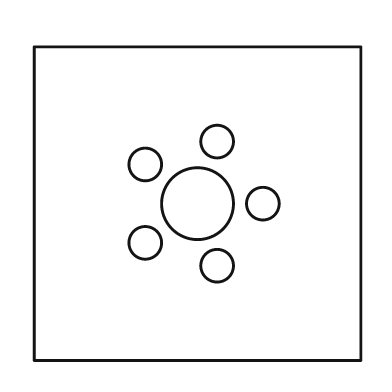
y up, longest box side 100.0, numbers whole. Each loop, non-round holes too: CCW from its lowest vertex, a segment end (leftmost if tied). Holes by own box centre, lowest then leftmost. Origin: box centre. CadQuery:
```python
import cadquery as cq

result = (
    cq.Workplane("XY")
    .moveTo(-50.0, -48.0)
    .lineTo(50.0, -48.0)
    .lineTo(50.0, 48.0)
    .lineTo(-50.0, 48.0)
    .close()
    .moveTo(6.0, -19.0)
    .circle(5.0)
    .moveTo(-16.0, -12.0)
    .circle(5.0)
    .moveTo(0.0, 0.0)
    .circle(11.0)
    .moveTo(20.0, 0.0)
    .circle(5.0)
    .moveTo(-16.0, 12.0)
    .circle(5.0)
    .moveTo(6.0, 19.0)
    .circle(5.0)
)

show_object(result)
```